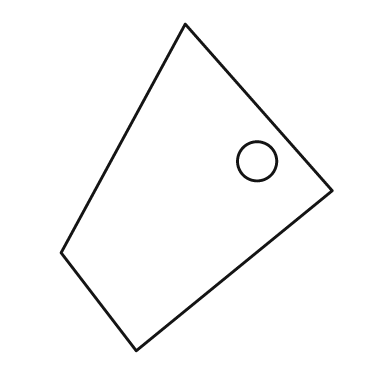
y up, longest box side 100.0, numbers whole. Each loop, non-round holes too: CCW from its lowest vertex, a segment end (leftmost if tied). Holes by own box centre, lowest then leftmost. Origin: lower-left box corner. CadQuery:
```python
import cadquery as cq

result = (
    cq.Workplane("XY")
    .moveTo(23.0, 0.0)
    .lineTo(83.0, 49.0)
    .lineTo(38.0, 100.0)
    .lineTo(0.0, 30.0)
    .close()
    .moveTo(60.0, 58.0)
    .circle(6.0)
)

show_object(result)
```